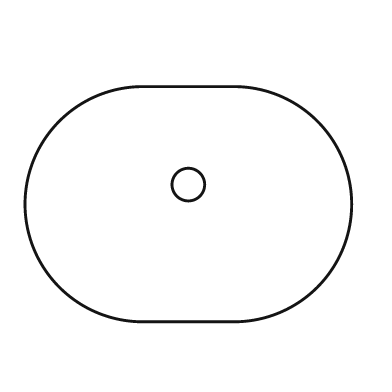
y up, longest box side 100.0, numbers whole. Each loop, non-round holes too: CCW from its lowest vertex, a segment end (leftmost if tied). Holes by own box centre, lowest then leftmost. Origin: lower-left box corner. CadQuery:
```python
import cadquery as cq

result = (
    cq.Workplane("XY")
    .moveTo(36.0, 0.0)
    .lineTo(64.0, 0.0)
    .threePointArc((100.0, 36.0), (64.0, 72.0))
    .lineTo(36.0, 72.0)
    .threePointArc((0.0, 36.0), (36.0, 0.0))
    .close()
    .moveTo(50.0, 42.0)
    .circle(5.0)
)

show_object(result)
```